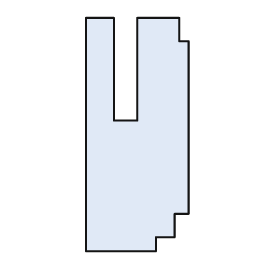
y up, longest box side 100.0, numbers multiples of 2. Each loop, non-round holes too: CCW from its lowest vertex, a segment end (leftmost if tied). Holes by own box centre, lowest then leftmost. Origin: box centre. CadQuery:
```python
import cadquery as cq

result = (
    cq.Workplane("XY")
    .moveTo(-22.0, -50.0)
    .lineTo(8.0, -50.0)
    .lineTo(8.0, -44.0)
    .lineTo(16.0, -44.0)
    .lineTo(16.0, -34.0)
    .lineTo(22.0, -34.0)
    .lineTo(22.0, 40.0)
    .lineTo(18.0, 40.0)
    .lineTo(18.0, 50.0)
    .lineTo(0.0, 50.0)
    .lineTo(0.0, 6.0)
    .lineTo(-10.0, 6.0)
    .lineTo(-10.0, 50.0)
    .lineTo(-22.0, 50.0)
    .close()
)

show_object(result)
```